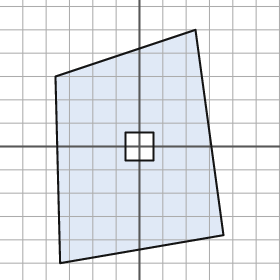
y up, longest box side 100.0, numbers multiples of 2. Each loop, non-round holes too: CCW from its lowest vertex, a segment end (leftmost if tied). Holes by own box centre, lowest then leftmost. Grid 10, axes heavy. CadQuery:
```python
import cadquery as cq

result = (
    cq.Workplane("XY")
    .moveTo(-34.0, -50.0)
    .lineTo(36.0, -38.0)
    .lineTo(24.0, 50.0)
    .lineTo(-36.0, 30.0)
    .close()
    .moveTo(-6.0, -6.0)
    .lineTo(6.0, -6.0)
    .lineTo(6.0, 6.0)
    .lineTo(-6.0, 6.0)
    .close()
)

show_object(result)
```